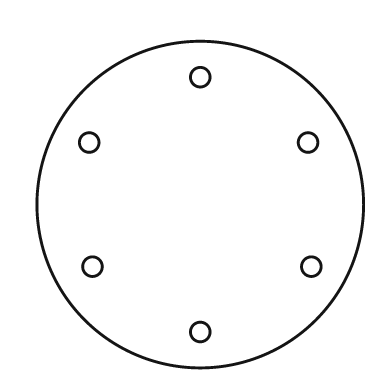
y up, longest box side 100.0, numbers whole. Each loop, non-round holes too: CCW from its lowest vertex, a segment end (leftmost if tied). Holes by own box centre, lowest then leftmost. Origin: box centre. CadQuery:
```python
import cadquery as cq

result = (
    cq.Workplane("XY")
    .moveTo(0.0, 0.0)
    .circle(50.0)
    .moveTo(0.0, -39.0)
    .circle(3.0)
    .moveTo(-33.0, -19.0)
    .circle(3.0)
    .moveTo(34.0, -19.0)
    .circle(3.0)
    .moveTo(-34.0, 19.0)
    .circle(3.0)
    .moveTo(33.0, 19.0)
    .circle(3.0)
    .moveTo(0.0, 39.0)
    .circle(3.0)
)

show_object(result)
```